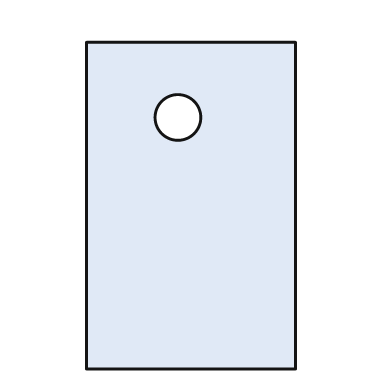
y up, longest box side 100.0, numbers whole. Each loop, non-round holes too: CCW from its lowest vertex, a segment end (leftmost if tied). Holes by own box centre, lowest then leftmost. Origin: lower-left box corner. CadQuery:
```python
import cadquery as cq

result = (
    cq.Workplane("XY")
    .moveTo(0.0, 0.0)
    .lineTo(64.0, 0.0)
    .lineTo(64.0, 100.0)
    .lineTo(0.0, 100.0)
    .close()
    .moveTo(28.0, 77.0)
    .circle(7.0)
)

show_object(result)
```